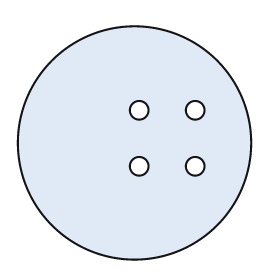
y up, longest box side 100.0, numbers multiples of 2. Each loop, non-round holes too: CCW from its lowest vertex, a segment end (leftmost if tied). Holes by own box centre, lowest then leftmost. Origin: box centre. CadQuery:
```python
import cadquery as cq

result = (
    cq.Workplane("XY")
    .moveTo(0.0, 0.0)
    .circle(50.0)
    .moveTo(2.0, -10.0)
    .circle(4.0)
    .moveTo(26.0, -10.0)
    .circle(4.0)
    .moveTo(2.0, 14.0)
    .circle(4.0)
    .moveTo(26.0, 14.0)
    .circle(4.0)
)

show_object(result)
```